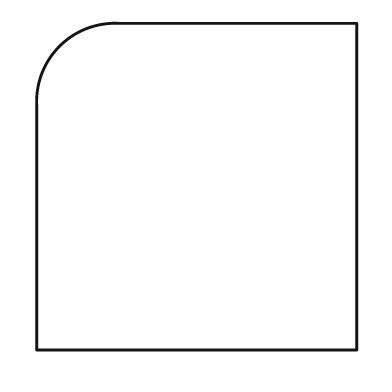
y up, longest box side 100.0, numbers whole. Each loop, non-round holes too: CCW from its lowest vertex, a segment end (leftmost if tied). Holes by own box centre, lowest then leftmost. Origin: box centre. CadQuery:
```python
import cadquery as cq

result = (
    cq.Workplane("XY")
    .moveTo(-49.0, -50.0)
    .lineTo(49.0, -50.0)
    .lineTo(49.0, 50.0)
    .lineTo(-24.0, 50.0)
    .threePointArc((-42.0, 43.0), (-49.0, 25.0))
    .close()
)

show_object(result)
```